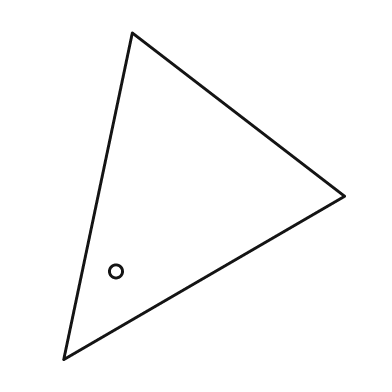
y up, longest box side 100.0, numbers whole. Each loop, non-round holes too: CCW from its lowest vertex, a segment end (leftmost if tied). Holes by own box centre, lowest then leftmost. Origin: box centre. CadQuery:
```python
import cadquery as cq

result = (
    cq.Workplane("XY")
    .moveTo(-43.0, -50.0)
    .lineTo(43.0, 0.0)
    .lineTo(-22.0, 50.0)
    .close()
    .moveTo(-27.0, -23.0)
    .circle(2.0)
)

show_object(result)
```